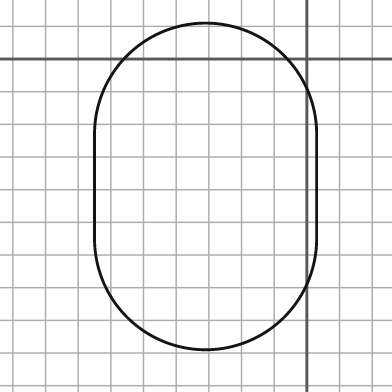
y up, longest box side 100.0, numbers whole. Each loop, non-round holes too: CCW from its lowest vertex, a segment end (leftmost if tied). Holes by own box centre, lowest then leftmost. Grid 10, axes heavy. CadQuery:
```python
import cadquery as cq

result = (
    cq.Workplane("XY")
    .moveTo(-65.0, -55.0)
    .threePointArc((-31.0, -89.0), (3.0, -55.0))
    .lineTo(3.0, -23.0)
    .threePointArc((-31.0, 11.0), (-65.0, -23.0))
    .close()
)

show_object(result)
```